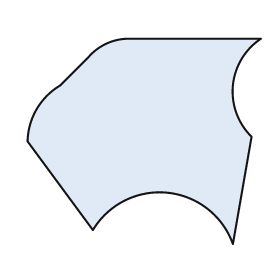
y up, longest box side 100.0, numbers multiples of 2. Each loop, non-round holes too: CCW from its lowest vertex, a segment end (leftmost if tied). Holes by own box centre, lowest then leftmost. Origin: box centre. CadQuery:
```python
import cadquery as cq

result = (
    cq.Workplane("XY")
    .moveTo(38.0, -44.0)
    .lineTo(46.0, 2.0)
    .threePointArc((38.0, 24.0), (50.0, 44.0))
    .lineTo(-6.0, 44.0)
    .threePointArc((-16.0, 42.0), (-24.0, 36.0))
    .lineTo(-36.0, 24.0)
    .threePointArc((-46.0, 14.0), (-50.0, 0.0))
    .lineTo(-22.0, -38.0)
    .threePointArc((10.0, -22.0), (38.0, -44.0))
    .close()
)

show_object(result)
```